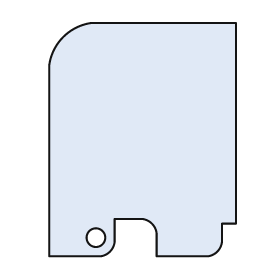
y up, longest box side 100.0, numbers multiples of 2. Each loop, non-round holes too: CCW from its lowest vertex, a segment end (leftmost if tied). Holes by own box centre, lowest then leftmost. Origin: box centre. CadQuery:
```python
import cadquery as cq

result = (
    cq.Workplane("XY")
    .moveTo(-40.0, -50.0)
    .lineTo(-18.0, -50.0)
    .threePointArc((-14.0, -48.0), (-12.0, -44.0))
    .lineTo(-12.0, -34.0)
    .lineTo(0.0, -34.0)
    .threePointArc((4.0, -36.0), (6.0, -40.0))
    .lineTo(6.0, -50.0)
    .lineTo(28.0, -50.0)
    .threePointArc((32.0, -48.0), (34.0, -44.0))
    .lineTo(34.0, -36.0)
    .lineTo(40.0, -36.0)
    .lineTo(40.0, 50.0)
    .lineTo(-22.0, 50.0)
    .threePointArc((-34.0, 44.0), (-40.0, 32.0))
    .close()
    .moveTo(-20.0, -42.0)
    .circle(4.0)
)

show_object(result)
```